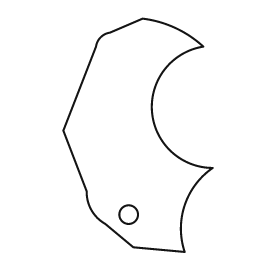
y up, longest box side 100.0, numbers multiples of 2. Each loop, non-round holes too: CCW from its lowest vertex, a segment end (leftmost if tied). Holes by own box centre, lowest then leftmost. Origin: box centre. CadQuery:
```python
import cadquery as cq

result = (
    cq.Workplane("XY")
    .moveTo(20.0, -50.0)
    .threePointArc((20.0, -30.0), (32.0, -14.0))
    .threePointArc((6.0, 10.0), (28.0, 38.0))
    .threePointArc((16.0, 46.0), (2.0, 50.0))
    .lineTo(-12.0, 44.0)
    .threePointArc((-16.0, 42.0), (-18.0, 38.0))
    .lineTo(-32.0, 2.0)
    .lineTo(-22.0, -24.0)
    .threePointArc((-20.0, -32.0), (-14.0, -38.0))
    .lineTo(-2.0, -48.0)
    .close()
    .moveTo(-4.0, -34.0)
    .circle(4.0)
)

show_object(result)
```